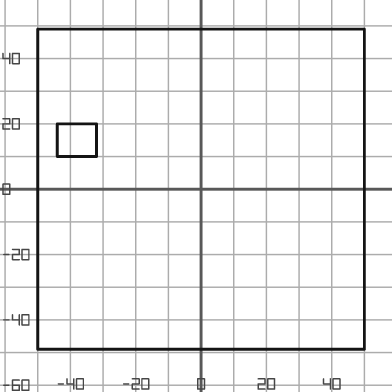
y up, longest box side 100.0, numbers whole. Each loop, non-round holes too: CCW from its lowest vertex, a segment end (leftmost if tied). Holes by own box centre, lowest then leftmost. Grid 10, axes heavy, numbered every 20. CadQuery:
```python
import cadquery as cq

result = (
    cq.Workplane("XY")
    .moveTo(-50.0, -49.0)
    .lineTo(50.0, -49.0)
    .lineTo(50.0, 49.0)
    .lineTo(-50.0, 49.0)
    .close()
    .moveTo(-44.0, 10.0)
    .lineTo(-32.0, 10.0)
    .lineTo(-32.0, 20.0)
    .lineTo(-44.0, 20.0)
    .close()
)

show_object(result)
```